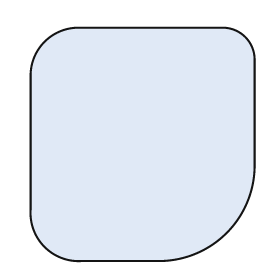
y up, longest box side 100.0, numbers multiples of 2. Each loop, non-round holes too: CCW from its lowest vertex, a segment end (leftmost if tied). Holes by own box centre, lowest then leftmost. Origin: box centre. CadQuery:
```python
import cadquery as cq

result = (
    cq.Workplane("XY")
    .moveTo(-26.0, -50.0)
    .lineTo(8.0, -50.0)
    .threePointArc((36.0, -38.0), (48.0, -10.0))
    .lineTo(48.0, 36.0)
    .threePointArc((44.0, 46.0), (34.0, 50.0))
    .lineTo(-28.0, 50.0)
    .threePointArc((-42.0, 44.0), (-48.0, 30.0))
    .lineTo(-48.0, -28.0)
    .threePointArc((-42.0, -44.0), (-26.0, -50.0))
    .close()
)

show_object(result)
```